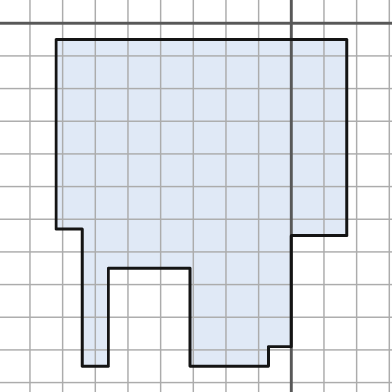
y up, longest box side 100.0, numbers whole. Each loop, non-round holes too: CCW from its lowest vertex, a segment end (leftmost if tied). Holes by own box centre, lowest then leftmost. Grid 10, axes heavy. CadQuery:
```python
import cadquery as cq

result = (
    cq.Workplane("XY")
    .moveTo(-64.0, -105.0)
    .lineTo(-56.0, -105.0)
    .lineTo(-56.0, -75.0)
    .lineTo(-31.0, -75.0)
    .lineTo(-31.0, -105.0)
    .lineTo(-7.0, -105.0)
    .lineTo(-7.0, -99.0)
    .lineTo(0.0, -99.0)
    .lineTo(0.0, -65.0)
    .lineTo(17.0, -65.0)
    .lineTo(17.0, -5.0)
    .lineTo(-72.0, -5.0)
    .lineTo(-72.0, -63.0)
    .lineTo(-64.0, -63.0)
    .close()
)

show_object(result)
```